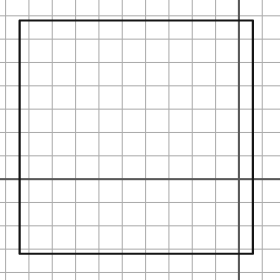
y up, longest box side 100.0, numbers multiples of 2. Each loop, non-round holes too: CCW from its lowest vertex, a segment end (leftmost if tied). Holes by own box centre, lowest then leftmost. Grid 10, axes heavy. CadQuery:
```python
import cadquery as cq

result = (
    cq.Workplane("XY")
    .moveTo(-94.0, -32.0)
    .lineTo(6.0, -32.0)
    .lineTo(6.0, 68.0)
    .lineTo(-94.0, 68.0)
    .close()
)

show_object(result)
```